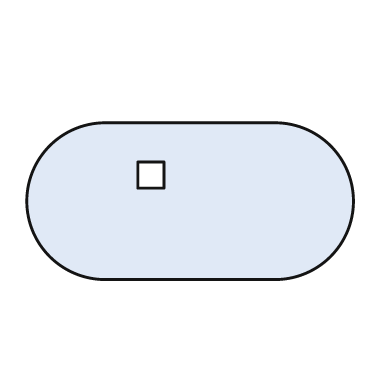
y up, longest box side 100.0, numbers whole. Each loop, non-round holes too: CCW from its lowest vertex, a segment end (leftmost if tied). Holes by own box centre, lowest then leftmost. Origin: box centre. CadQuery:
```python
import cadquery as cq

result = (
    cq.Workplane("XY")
    .moveTo(-26.0, -24.0)
    .lineTo(26.0, -24.0)
    .threePointArc((50.0, 0.0), (26.0, 24.0))
    .lineTo(-26.0, 24.0)
    .threePointArc((-50.0, 0.0), (-26.0, -24.0))
    .close()
    .moveTo(-16.0, 4.0)
    .lineTo(-8.0, 4.0)
    .lineTo(-8.0, 12.0)
    .lineTo(-16.0, 12.0)
    .close()
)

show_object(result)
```